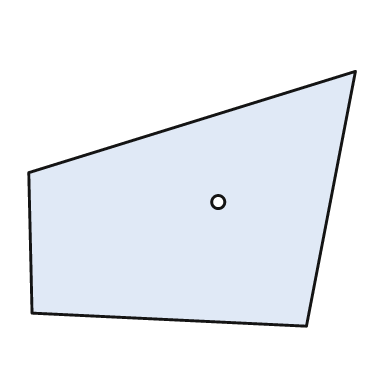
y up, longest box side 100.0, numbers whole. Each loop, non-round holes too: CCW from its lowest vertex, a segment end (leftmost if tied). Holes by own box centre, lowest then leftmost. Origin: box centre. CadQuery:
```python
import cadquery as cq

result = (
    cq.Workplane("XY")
    .moveTo(35.0, -39.0)
    .lineTo(50.0, 39.0)
    .lineTo(-50.0, 8.0)
    .lineTo(-49.0, -35.0)
    .close()
    .moveTo(8.0, -1.0)
    .circle(2.0)
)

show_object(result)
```